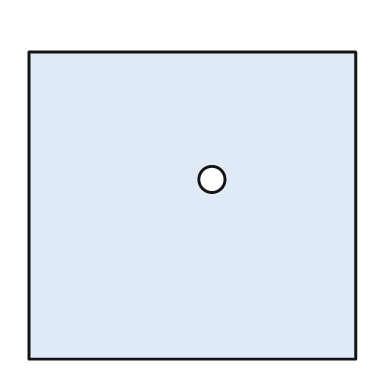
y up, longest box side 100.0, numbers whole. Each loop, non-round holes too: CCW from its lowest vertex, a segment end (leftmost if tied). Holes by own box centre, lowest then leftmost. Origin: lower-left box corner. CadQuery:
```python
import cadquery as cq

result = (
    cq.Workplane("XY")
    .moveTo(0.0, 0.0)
    .lineTo(100.0, 0.0)
    .lineTo(100.0, 94.0)
    .lineTo(0.0, 94.0)
    .close()
    .moveTo(56.0, 55.0)
    .circle(4.0)
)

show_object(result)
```